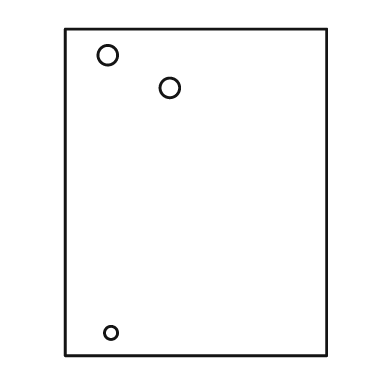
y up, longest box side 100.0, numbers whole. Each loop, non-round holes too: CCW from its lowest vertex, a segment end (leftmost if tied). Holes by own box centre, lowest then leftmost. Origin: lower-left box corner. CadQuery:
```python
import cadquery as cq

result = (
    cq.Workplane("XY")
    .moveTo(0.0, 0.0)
    .lineTo(80.0, 0.0)
    .lineTo(80.0, 100.0)
    .lineTo(0.0, 100.0)
    .close()
    .moveTo(14.0, 7.0)
    .circle(2.0)
    .moveTo(32.0, 82.0)
    .circle(3.0)
    .moveTo(13.0, 92.0)
    .circle(3.0)
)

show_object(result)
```